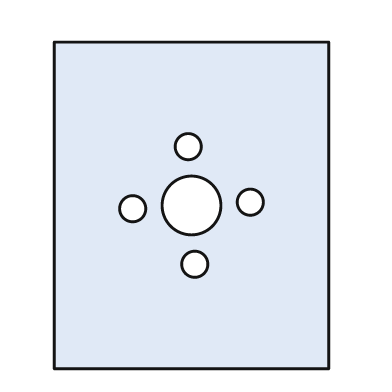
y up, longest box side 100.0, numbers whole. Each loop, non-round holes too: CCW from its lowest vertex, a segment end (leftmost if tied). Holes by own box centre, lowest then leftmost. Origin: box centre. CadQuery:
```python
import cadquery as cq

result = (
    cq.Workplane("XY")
    .moveTo(-42.0, -50.0)
    .lineTo(42.0, -50.0)
    .lineTo(42.0, 50.0)
    .lineTo(-42.0, 50.0)
    .close()
    .moveTo(1.0, -18.0)
    .circle(4.0)
    .moveTo(-18.0, -1.0)
    .circle(4.0)
    .moveTo(0.0, 0.0)
    .circle(9.0)
    .moveTo(18.0, 1.0)
    .circle(4.0)
    .moveTo(-1.0, 18.0)
    .circle(4.0)
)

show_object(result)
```